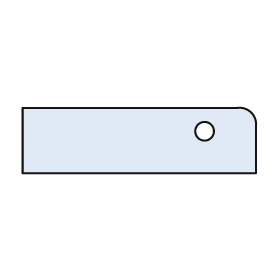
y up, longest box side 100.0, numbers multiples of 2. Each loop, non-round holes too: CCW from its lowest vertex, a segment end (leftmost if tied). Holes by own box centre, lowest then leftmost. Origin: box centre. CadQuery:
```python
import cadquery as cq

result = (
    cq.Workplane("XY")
    .moveTo(-50.0, -14.0)
    .lineTo(50.0, -14.0)
    .lineTo(50.0, 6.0)
    .threePointArc((48.0, 12.0), (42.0, 14.0))
    .lineTo(-50.0, 14.0)
    .close()
    .moveTo(28.0, 4.0)
    .circle(4.0)
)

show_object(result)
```